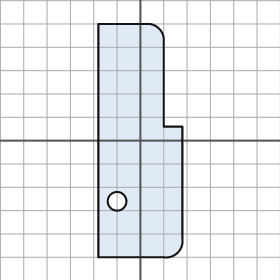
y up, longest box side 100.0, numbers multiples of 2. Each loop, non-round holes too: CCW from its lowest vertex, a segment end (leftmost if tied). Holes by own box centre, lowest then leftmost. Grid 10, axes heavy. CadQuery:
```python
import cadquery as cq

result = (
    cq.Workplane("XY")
    .moveTo(-18.0, -50.0)
    .lineTo(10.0, -50.0)
    .threePointArc((16.0, -48.0), (18.0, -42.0))
    .lineTo(18.0, 6.0)
    .lineTo(10.0, 6.0)
    .lineTo(10.0, 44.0)
    .threePointArc((8.0, 48.0), (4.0, 50.0))
    .lineTo(-18.0, 50.0)
    .close()
    .moveTo(-10.0, -26.0)
    .circle(4.0)
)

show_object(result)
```